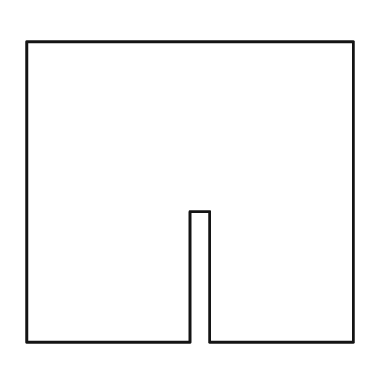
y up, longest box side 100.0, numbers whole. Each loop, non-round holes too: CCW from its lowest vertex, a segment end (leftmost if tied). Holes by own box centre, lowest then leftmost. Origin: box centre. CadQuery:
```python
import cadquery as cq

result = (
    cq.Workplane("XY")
    .moveTo(-50.0, -46.0)
    .lineTo(0.0, -46.0)
    .lineTo(0.0, -6.0)
    .lineTo(6.0, -6.0)
    .lineTo(6.0, -46.0)
    .lineTo(50.0, -46.0)
    .lineTo(50.0, 46.0)
    .lineTo(-50.0, 46.0)
    .close()
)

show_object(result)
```